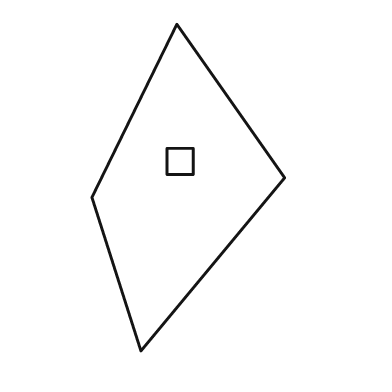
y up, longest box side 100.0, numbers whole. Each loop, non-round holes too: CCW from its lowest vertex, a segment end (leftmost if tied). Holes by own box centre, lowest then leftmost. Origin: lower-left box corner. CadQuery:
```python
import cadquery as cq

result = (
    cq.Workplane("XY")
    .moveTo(15.0, 0.0)
    .lineTo(59.0, 53.0)
    .lineTo(26.0, 100.0)
    .lineTo(0.0, 47.0)
    .close()
    .moveTo(23.0, 54.0)
    .lineTo(31.0, 54.0)
    .lineTo(31.0, 62.0)
    .lineTo(23.0, 62.0)
    .close()
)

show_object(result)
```